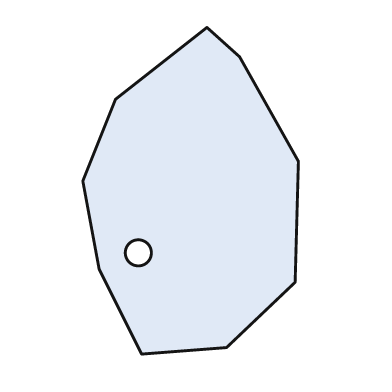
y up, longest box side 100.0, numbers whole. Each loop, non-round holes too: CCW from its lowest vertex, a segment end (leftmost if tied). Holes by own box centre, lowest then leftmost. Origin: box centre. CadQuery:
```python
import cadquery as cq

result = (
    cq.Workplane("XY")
    .moveTo(-15.0, -50.0)
    .lineTo(11.0, -48.0)
    .lineTo(32.0, -28.0)
    .lineTo(33.0, 9.0)
    .lineTo(15.0, 41.0)
    .lineTo(5.0, 50.0)
    .lineTo(-23.0, 28.0)
    .lineTo(-33.0, 3.0)
    .lineTo(-28.0, -24.0)
    .close()
    .moveTo(-16.0, -19.0)
    .circle(4.0)
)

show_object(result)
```